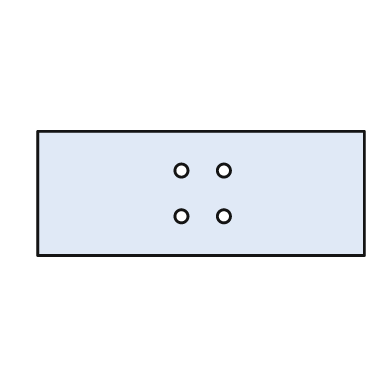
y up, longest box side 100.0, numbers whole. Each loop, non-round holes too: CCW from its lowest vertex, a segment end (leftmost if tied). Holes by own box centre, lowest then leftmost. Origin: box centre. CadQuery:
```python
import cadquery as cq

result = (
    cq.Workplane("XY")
    .moveTo(-50.0, -19.0)
    .lineTo(50.0, -19.0)
    .lineTo(50.0, 19.0)
    .lineTo(-50.0, 19.0)
    .close()
    .moveTo(-6.0, -7.0)
    .circle(2.0)
    .moveTo(7.0, -7.0)
    .circle(2.0)
    .moveTo(-6.0, 7.0)
    .circle(2.0)
    .moveTo(7.0, 7.0)
    .circle(2.0)
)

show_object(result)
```